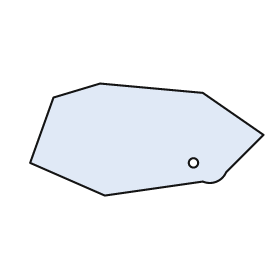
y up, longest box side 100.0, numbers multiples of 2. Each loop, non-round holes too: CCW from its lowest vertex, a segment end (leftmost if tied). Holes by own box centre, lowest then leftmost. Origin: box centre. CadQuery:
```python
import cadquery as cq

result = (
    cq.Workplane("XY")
    .moveTo(-18.0, -24.0)
    .lineTo(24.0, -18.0)
    .threePointArc((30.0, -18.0), (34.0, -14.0))
    .lineTo(50.0, 2.0)
    .lineTo(24.0, 20.0)
    .lineTo(-20.0, 24.0)
    .lineTo(-40.0, 18.0)
    .lineTo(-50.0, -10.0)
    .close()
    .moveTo(20.0, -10.0)
    .circle(2.0)
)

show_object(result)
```